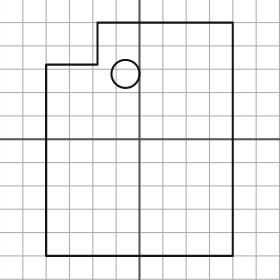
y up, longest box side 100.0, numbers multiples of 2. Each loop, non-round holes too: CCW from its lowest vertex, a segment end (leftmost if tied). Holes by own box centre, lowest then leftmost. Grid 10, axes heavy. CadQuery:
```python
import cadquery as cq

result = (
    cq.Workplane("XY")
    .moveTo(-40.0, -50.0)
    .lineTo(40.0, -50.0)
    .lineTo(40.0, 50.0)
    .lineTo(-18.0, 50.0)
    .lineTo(-18.0, 32.0)
    .lineTo(-40.0, 32.0)
    .close()
    .moveTo(-6.0, 28.0)
    .circle(6.0)
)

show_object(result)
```